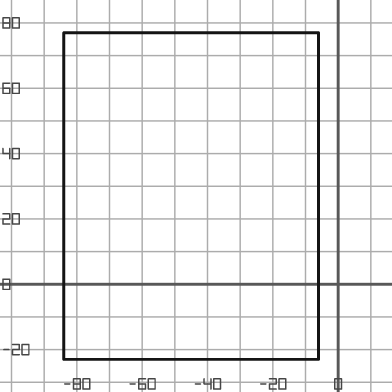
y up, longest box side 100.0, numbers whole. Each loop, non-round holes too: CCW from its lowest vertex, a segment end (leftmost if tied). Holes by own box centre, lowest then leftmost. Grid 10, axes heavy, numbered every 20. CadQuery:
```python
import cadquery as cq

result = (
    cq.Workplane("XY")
    .moveTo(-84.0, -23.0)
    .lineTo(-6.0, -23.0)
    .lineTo(-6.0, 77.0)
    .lineTo(-84.0, 77.0)
    .close()
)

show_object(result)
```